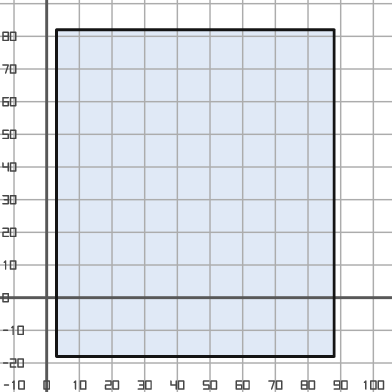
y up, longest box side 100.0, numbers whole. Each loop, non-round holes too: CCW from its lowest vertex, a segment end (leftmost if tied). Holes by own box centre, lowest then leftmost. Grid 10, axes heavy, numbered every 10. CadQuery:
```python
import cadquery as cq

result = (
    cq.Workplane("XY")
    .moveTo(3.0, -18.0)
    .lineTo(88.0, -18.0)
    .lineTo(88.0, 82.0)
    .lineTo(3.0, 82.0)
    .close()
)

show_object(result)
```